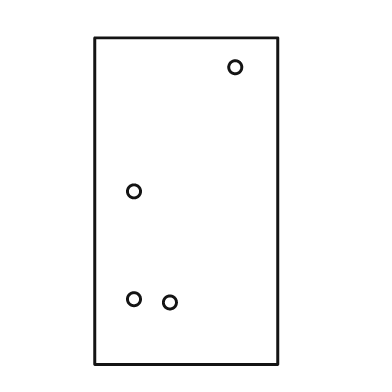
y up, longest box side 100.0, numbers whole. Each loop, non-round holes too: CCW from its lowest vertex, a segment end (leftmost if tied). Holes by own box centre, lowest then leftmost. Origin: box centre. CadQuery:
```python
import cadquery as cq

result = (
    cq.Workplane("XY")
    .moveTo(-28.0, -50.0)
    .lineTo(28.0, -50.0)
    .lineTo(28.0, 50.0)
    .lineTo(-28.0, 50.0)
    .close()
    .moveTo(-5.0, -31.0)
    .circle(2.0)
    .moveTo(-16.0, -30.0)
    .circle(2.0)
    .moveTo(-16.0, 3.0)
    .circle(2.0)
    .moveTo(15.0, 41.0)
    .circle(2.0)
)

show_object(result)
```